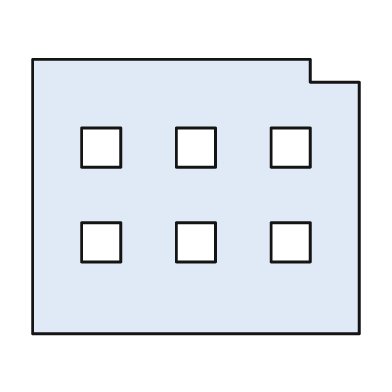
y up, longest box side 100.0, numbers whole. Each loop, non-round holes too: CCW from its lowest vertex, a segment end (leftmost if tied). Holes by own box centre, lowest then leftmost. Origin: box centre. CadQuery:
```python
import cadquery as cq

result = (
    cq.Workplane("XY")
    .moveTo(-50.0, -42.0)
    .lineTo(50.0, -42.0)
    .lineTo(50.0, 35.0)
    .lineTo(35.0, 35.0)
    .lineTo(35.0, 42.0)
    .lineTo(-50.0, 42.0)
    .close()
    .moveTo(-35.0, -20.0)
    .lineTo(-23.0, -20.0)
    .lineTo(-23.0, -8.0)
    .lineTo(-35.0, -8.0)
    .close()
    .moveTo(-6.0, -20.0)
    .lineTo(6.0, -20.0)
    .lineTo(6.0, -8.0)
    .lineTo(-6.0, -8.0)
    .close()
    .moveTo(23.0, -20.0)
    .lineTo(35.0, -20.0)
    .lineTo(35.0, -8.0)
    .lineTo(23.0, -8.0)
    .close()
    .moveTo(-35.0, 9.0)
    .lineTo(-23.0, 9.0)
    .lineTo(-23.0, 21.0)
    .lineTo(-35.0, 21.0)
    .close()
    .moveTo(-6.0, 9.0)
    .lineTo(6.0, 9.0)
    .lineTo(6.0, 21.0)
    .lineTo(-6.0, 21.0)
    .close()
    .moveTo(23.0, 9.0)
    .lineTo(35.0, 9.0)
    .lineTo(35.0, 21.0)
    .lineTo(23.0, 21.0)
    .close()
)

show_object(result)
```